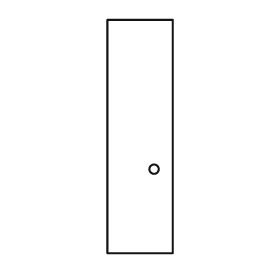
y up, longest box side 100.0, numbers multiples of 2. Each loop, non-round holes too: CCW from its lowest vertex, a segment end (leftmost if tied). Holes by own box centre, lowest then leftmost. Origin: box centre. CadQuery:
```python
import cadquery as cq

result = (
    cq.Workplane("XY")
    .moveTo(-14.0, -50.0)
    .lineTo(14.0, -50.0)
    .lineTo(14.0, 50.0)
    .lineTo(-14.0, 50.0)
    .close()
    .moveTo(6.0, -14.0)
    .circle(2.0)
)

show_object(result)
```